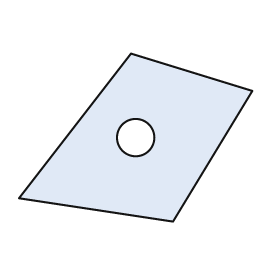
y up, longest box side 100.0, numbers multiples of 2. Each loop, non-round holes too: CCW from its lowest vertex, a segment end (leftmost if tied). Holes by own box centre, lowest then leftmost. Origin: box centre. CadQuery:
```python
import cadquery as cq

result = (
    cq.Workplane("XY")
    .moveTo(16.0, -36.0)
    .lineTo(50.0, 20.0)
    .lineTo(-2.0, 36.0)
    .lineTo(-50.0, -26.0)
    .close()
    .moveTo(0.0, 0.0)
    .circle(8.0)
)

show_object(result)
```